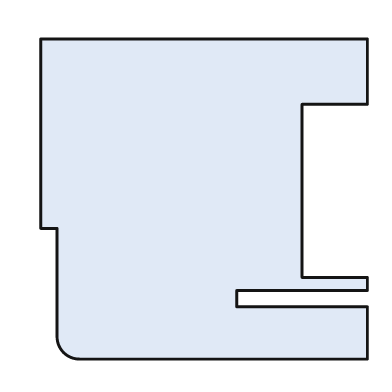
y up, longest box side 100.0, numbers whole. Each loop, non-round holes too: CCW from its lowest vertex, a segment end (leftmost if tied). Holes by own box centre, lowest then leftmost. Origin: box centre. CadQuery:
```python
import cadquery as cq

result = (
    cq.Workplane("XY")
    .moveTo(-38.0, -49.0)
    .lineTo(50.0, -49.0)
    .lineTo(50.0, -33.0)
    .lineTo(10.0, -33.0)
    .lineTo(10.0, -28.0)
    .lineTo(50.0, -28.0)
    .lineTo(50.0, -24.0)
    .lineTo(30.0, -24.0)
    .lineTo(30.0, 29.0)
    .lineTo(50.0, 29.0)
    .lineTo(50.0, 49.0)
    .lineTo(-50.0, 49.0)
    .lineTo(-50.0, -9.0)
    .lineTo(-45.0, -9.0)
    .lineTo(-45.0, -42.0)
    .threePointArc((-43.0, -47.0), (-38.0, -49.0))
    .close()
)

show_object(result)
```